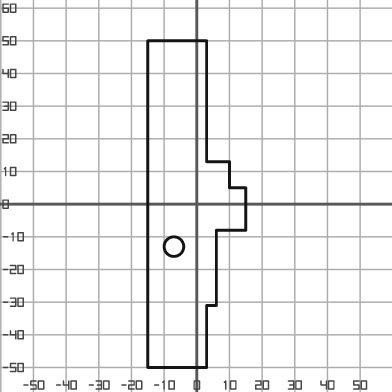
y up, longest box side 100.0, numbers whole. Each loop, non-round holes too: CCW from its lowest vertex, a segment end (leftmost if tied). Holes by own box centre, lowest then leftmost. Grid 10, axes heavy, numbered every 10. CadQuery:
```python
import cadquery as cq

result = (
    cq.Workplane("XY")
    .moveTo(-15.0, -50.0)
    .lineTo(3.0, -50.0)
    .lineTo(3.0, -31.0)
    .lineTo(6.0, -31.0)
    .lineTo(6.0, -8.0)
    .lineTo(15.0, -8.0)
    .lineTo(15.0, 5.0)
    .lineTo(10.0, 5.0)
    .lineTo(10.0, 13.0)
    .lineTo(3.0, 13.0)
    .lineTo(3.0, 50.0)
    .lineTo(-15.0, 50.0)
    .close()
    .moveTo(-7.0, -13.0)
    .circle(3.0)
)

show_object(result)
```